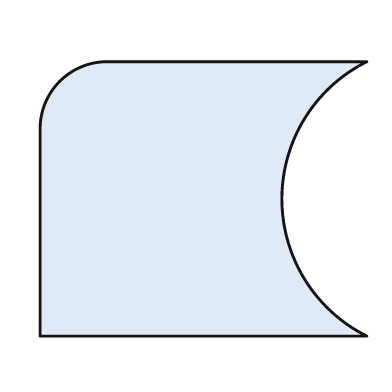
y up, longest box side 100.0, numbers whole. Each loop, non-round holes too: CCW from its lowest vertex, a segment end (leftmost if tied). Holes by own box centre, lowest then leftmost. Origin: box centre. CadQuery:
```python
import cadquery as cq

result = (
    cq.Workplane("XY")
    .moveTo(-50.0, -42.0)
    .lineTo(50.0, -42.0)
    .threePointArc((24.0, 0.0), (50.0, 42.0))
    .lineTo(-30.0, 42.0)
    .threePointArc((-44.0, 36.0), (-50.0, 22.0))
    .close()
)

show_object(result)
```